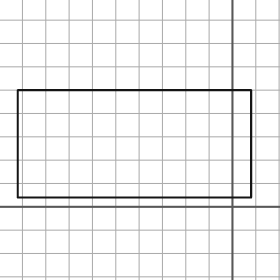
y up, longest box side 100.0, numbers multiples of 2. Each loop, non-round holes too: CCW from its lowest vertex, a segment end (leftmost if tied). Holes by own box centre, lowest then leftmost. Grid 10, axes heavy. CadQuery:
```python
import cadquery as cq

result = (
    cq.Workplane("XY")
    .moveTo(-92.0, 4.0)
    .lineTo(8.0, 4.0)
    .lineTo(8.0, 50.0)
    .lineTo(-92.0, 50.0)
    .close()
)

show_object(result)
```